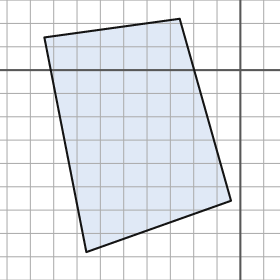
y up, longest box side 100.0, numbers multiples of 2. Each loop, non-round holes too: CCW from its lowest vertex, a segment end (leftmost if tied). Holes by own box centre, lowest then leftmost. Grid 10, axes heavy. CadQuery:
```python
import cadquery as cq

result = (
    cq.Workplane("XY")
    .moveTo(-66.0, -78.0)
    .lineTo(-4.0, -56.0)
    .lineTo(-26.0, 22.0)
    .lineTo(-84.0, 14.0)
    .close()
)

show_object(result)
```